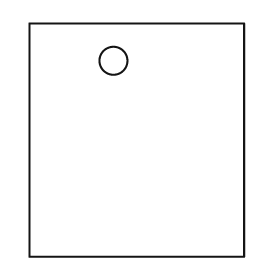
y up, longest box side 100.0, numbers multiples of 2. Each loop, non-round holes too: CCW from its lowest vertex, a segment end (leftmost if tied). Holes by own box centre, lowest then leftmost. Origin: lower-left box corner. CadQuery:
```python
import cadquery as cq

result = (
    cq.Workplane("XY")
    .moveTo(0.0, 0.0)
    .lineTo(92.0, 0.0)
    .lineTo(92.0, 100.0)
    .lineTo(0.0, 100.0)
    .close()
    .moveTo(36.0, 84.0)
    .circle(6.0)
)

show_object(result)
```